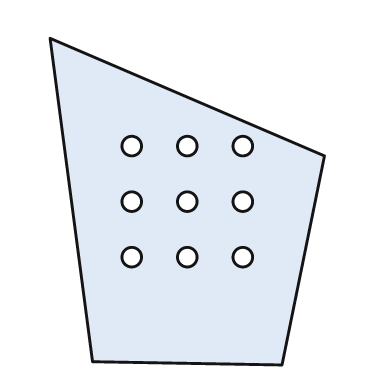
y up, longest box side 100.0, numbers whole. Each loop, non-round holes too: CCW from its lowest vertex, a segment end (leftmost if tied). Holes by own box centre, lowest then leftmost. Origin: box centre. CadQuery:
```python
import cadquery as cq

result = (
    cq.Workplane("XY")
    .moveTo(29.0, -50.0)
    .lineTo(42.0, 14.0)
    .lineTo(-42.0, 50.0)
    .lineTo(-29.0, -49.0)
    .close()
    .moveTo(-17.0, -17.0)
    .circle(3.0)
    .moveTo(0.0, -17.0)
    .circle(3.0)
    .moveTo(17.0, -17.0)
    .circle(3.0)
    .moveTo(-17.0, 0.0)
    .circle(3.0)
    .moveTo(0.0, 0.0)
    .circle(3.0)
    .moveTo(17.0, 0.0)
    .circle(3.0)
    .moveTo(-17.0, 17.0)
    .circle(3.0)
    .moveTo(0.0, 17.0)
    .circle(3.0)
    .moveTo(17.0, 17.0)
    .circle(3.0)
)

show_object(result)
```